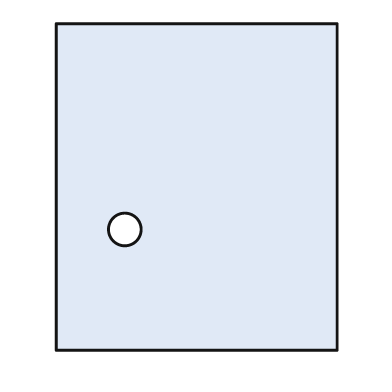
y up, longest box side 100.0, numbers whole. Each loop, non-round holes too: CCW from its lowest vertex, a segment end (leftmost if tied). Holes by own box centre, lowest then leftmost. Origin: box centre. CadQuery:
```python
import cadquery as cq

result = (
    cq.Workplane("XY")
    .moveTo(-43.0, -50.0)
    .lineTo(43.0, -50.0)
    .lineTo(43.0, 50.0)
    .lineTo(-43.0, 50.0)
    .close()
    .moveTo(-22.0, -13.0)
    .circle(5.0)
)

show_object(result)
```